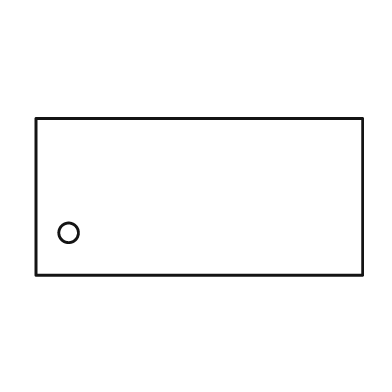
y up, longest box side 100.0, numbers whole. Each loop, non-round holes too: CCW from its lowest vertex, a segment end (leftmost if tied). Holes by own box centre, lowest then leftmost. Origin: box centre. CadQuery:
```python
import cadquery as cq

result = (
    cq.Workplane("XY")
    .moveTo(-50.0, -24.0)
    .lineTo(50.0, -24.0)
    .lineTo(50.0, 24.0)
    .lineTo(-50.0, 24.0)
    .close()
    .moveTo(-40.0, -11.0)
    .circle(3.0)
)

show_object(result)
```